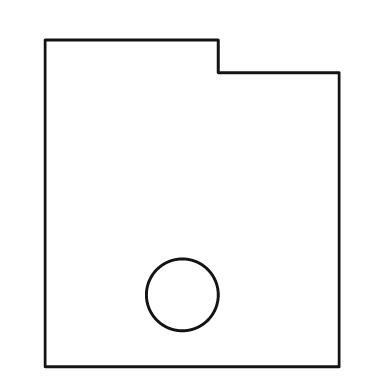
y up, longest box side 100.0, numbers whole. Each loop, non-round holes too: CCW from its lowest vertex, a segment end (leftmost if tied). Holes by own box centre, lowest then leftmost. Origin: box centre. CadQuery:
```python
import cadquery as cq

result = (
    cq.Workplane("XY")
    .moveTo(-45.0, -50.0)
    .lineTo(45.0, -50.0)
    .lineTo(45.0, 40.0)
    .lineTo(8.0, 40.0)
    .lineTo(8.0, 50.0)
    .lineTo(-45.0, 50.0)
    .close()
    .moveTo(-3.0, -28.0)
    .circle(11.0)
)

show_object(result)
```